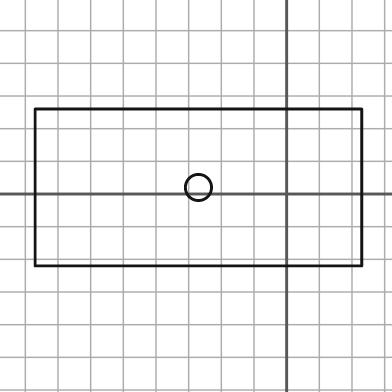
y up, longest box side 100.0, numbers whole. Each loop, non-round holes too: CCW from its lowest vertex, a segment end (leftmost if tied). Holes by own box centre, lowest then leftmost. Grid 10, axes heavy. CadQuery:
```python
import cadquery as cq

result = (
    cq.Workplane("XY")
    .moveTo(-77.0, -22.0)
    .lineTo(23.0, -22.0)
    .lineTo(23.0, 26.0)
    .lineTo(-77.0, 26.0)
    .close()
    .moveTo(-27.0, 2.0)
    .circle(4.0)
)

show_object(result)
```